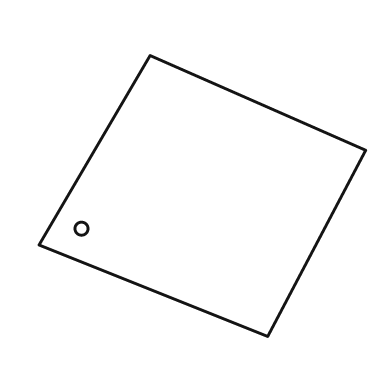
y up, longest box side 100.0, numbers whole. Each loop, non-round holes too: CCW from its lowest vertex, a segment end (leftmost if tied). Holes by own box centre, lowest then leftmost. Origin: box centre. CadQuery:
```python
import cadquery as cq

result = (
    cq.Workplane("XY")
    .moveTo(20.0, -43.0)
    .lineTo(50.0, 14.0)
    .lineTo(-16.0, 43.0)
    .lineTo(-50.0, -15.0)
    .close()
    .moveTo(-37.0, -10.0)
    .circle(2.0)
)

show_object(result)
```